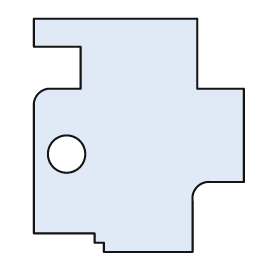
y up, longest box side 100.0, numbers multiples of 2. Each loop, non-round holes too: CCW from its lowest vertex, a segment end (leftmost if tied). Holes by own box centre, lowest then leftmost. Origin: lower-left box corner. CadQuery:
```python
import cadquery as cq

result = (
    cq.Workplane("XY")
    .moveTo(30.0, 0.0)
    .lineTo(68.0, 0.0)
    .lineTo(68.0, 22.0)
    .threePointArc((70.0, 28.0), (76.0, 30.0))
    .lineTo(90.0, 30.0)
    .lineTo(90.0, 70.0)
    .lineTo(70.0, 70.0)
    .lineTo(70.0, 100.0)
    .lineTo(0.0, 100.0)
    .lineTo(0.0, 88.0)
    .lineTo(20.0, 88.0)
    .lineTo(20.0, 70.0)
    .lineTo(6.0, 70.0)
    .threePointArc((2.0, 68.0), (0.0, 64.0))
    .lineTo(0.0, 8.0)
    .lineTo(26.0, 8.0)
    .lineTo(26.0, 4.0)
    .lineTo(30.0, 4.0)
    .close()
    .moveTo(14.0, 42.0)
    .circle(8.0)
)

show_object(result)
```